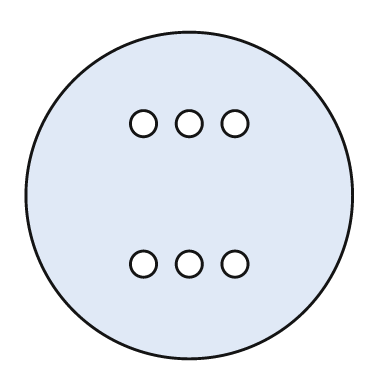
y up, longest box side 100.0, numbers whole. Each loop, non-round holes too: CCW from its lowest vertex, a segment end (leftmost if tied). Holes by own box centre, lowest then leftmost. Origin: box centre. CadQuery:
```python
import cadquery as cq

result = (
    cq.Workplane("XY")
    .moveTo(0.0, 0.0)
    .circle(50.0)
    .moveTo(-14.0, -21.0)
    .circle(4.0)
    .moveTo(0.0, -21.0)
    .circle(4.0)
    .moveTo(14.0, -21.0)
    .circle(4.0)
    .moveTo(-14.0, 22.0)
    .circle(4.0)
    .moveTo(0.0, 22.0)
    .circle(4.0)
    .moveTo(14.0, 22.0)
    .circle(4.0)
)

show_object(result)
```